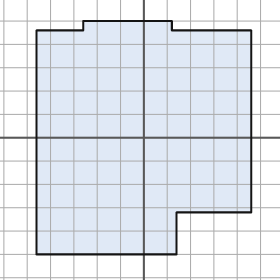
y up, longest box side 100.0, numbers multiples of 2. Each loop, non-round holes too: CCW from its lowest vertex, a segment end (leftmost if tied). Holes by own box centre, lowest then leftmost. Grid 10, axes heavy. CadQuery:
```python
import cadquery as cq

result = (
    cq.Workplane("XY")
    .moveTo(-46.0, -50.0)
    .lineTo(14.0, -50.0)
    .lineTo(14.0, -32.0)
    .lineTo(46.0, -32.0)
    .lineTo(46.0, 46.0)
    .lineTo(12.0, 46.0)
    .lineTo(12.0, 50.0)
    .lineTo(-26.0, 50.0)
    .lineTo(-26.0, 46.0)
    .lineTo(-46.0, 46.0)
    .close()
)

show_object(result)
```